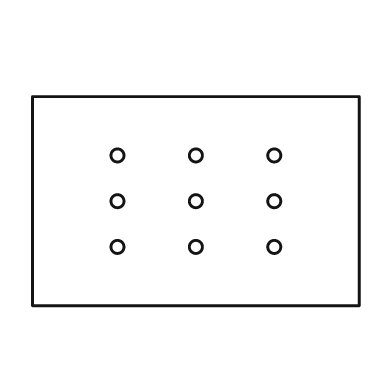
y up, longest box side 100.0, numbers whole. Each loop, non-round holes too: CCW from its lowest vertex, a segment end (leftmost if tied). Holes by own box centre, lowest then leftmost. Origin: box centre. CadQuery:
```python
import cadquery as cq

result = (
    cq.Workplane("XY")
    .moveTo(-50.0, -32.0)
    .lineTo(50.0, -32.0)
    .lineTo(50.0, 32.0)
    .lineTo(-50.0, 32.0)
    .close()
    .moveTo(-24.0, -14.0)
    .circle(2.0)
    .moveTo(0.0, -14.0)
    .circle(2.0)
    .moveTo(24.0, -14.0)
    .circle(2.0)
    .moveTo(-24.0, 0.0)
    .circle(2.0)
    .moveTo(0.0, 0.0)
    .circle(2.0)
    .moveTo(24.0, 0.0)
    .circle(2.0)
    .moveTo(-24.0, 14.0)
    .circle(2.0)
    .moveTo(0.0, 14.0)
    .circle(2.0)
    .moveTo(24.0, 14.0)
    .circle(2.0)
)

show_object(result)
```